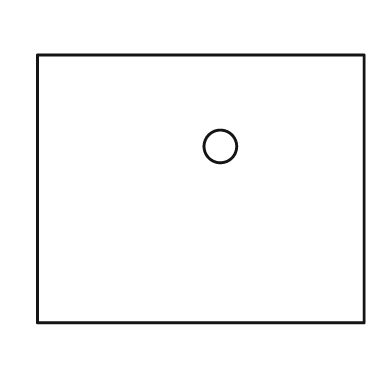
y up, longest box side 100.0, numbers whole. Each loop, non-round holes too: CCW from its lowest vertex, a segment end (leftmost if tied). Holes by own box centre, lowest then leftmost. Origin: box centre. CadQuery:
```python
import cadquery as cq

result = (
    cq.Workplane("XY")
    .moveTo(-50.0, -41.0)
    .lineTo(50.0, -41.0)
    .lineTo(50.0, 41.0)
    .lineTo(-50.0, 41.0)
    .close()
    .moveTo(6.0, 13.0)
    .circle(5.0)
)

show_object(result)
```